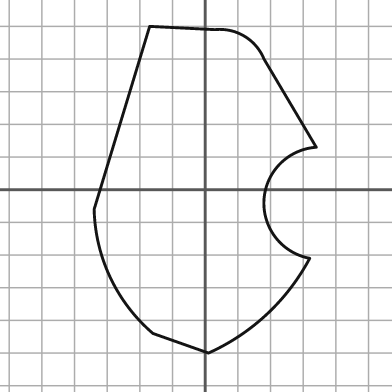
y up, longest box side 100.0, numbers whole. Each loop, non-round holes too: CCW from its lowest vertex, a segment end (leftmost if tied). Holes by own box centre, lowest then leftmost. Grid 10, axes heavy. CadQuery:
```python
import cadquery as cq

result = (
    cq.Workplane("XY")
    .moveTo(1.0, -50.0)
    .threePointArc((19.0, -38.0), (32.0, -21.0))
    .threePointArc((18.0, -3.0), (34.0, 13.0))
    .lineTo(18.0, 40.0)
    .threePointArc((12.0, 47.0), (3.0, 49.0))
    .lineTo(-17.0, 50.0)
    .lineTo(-34.0, -6.0)
    .threePointArc((-29.0, -27.0), (-16.0, -44.0))
    .close()
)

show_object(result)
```